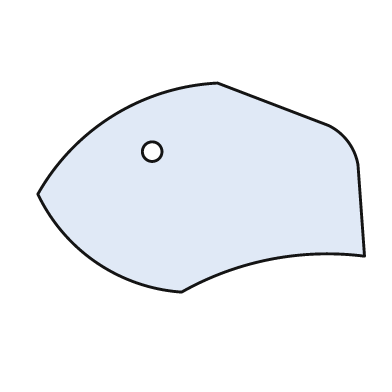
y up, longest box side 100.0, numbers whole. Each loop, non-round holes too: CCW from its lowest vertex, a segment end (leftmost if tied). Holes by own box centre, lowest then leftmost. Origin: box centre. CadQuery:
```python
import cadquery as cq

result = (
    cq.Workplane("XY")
    .moveTo(-6.0, -32.0)
    .threePointArc((21.0, -22.0), (50.0, -21.0))
    .lineTo(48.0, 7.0)
    .threePointArc((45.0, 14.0), (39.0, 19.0))
    .lineTo(5.0, 32.0)
    .threePointArc((-27.0, 22.0), (-50.0, -2.0))
    .threePointArc((-32.0, -23.0), (-6.0, -32.0))
    .close()
    .moveTo(-15.0, 11.0)
    .circle(3.0)
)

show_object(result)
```